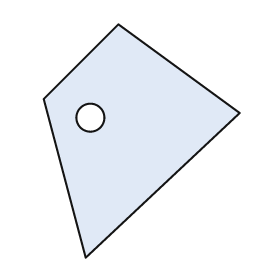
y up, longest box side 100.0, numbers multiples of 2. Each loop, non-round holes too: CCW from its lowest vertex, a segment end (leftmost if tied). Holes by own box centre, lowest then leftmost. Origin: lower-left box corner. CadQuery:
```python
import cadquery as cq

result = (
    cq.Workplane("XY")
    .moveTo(18.0, 0.0)
    .lineTo(84.0, 62.0)
    .lineTo(32.0, 100.0)
    .lineTo(0.0, 68.0)
    .close()
    .moveTo(20.0, 60.0)
    .circle(6.0)
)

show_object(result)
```